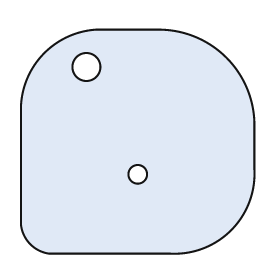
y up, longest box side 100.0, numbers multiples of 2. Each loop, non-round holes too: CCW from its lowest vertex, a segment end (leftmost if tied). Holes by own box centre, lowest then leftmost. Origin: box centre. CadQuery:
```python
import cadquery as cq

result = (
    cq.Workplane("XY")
    .moveTo(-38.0, -48.0)
    .lineTo(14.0, -48.0)
    .threePointArc((40.0, -38.0), (50.0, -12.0))
    .lineTo(50.0, 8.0)
    .threePointArc((38.0, 36.0), (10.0, 48.0))
    .lineTo(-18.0, 48.0)
    .threePointArc((-40.0, 38.0), (-50.0, 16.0))
    .lineTo(-50.0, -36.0)
    .threePointArc((-46.0, -44.0), (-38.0, -48.0))
    .close()
    .moveTo(0.0, -14.0)
    .circle(4.0)
    .moveTo(-22.0, 32.0)
    .circle(6.0)
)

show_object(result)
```